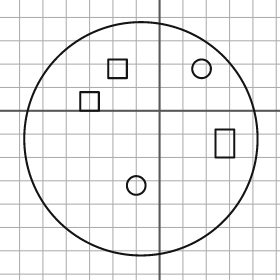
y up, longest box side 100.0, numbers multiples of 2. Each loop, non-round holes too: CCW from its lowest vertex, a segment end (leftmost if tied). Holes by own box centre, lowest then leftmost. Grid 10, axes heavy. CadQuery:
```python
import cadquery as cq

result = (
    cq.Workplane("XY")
    .moveTo(-8.0, -12.0)
    .circle(50.0)
    .moveTo(-10.0, -32.0)
    .circle(4.0)
    .moveTo(24.0, -20.0)
    .lineTo(32.0, -20.0)
    .lineTo(32.0, -8.0)
    .lineTo(24.0, -8.0)
    .close()
    .moveTo(-34.0, 0.0)
    .lineTo(-26.0, 0.0)
    .lineTo(-26.0, 8.0)
    .lineTo(-34.0, 8.0)
    .close()
    .moveTo(-22.0, 14.0)
    .lineTo(-14.0, 14.0)
    .lineTo(-14.0, 22.0)
    .lineTo(-22.0, 22.0)
    .close()
    .moveTo(18.0, 18.0)
    .circle(4.0)
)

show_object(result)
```